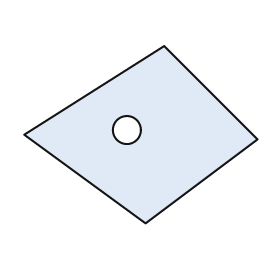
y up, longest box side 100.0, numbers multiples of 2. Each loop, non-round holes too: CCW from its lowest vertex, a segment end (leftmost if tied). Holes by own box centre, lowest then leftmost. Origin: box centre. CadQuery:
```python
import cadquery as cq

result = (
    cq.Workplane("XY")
    .moveTo(2.0, -38.0)
    .lineTo(50.0, -2.0)
    .lineTo(10.0, 38.0)
    .lineTo(-50.0, 0.0)
    .close()
    .moveTo(-6.0, 2.0)
    .circle(6.0)
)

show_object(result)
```